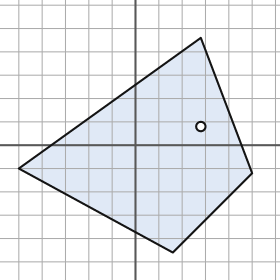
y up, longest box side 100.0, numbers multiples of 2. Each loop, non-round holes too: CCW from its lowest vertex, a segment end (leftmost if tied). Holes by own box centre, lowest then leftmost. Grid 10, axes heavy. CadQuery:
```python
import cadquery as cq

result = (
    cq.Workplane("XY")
    .moveTo(16.0, -46.0)
    .lineTo(50.0, -12.0)
    .lineTo(28.0, 46.0)
    .lineTo(-50.0, -10.0)
    .close()
    .moveTo(28.0, 8.0)
    .circle(2.0)
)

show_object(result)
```